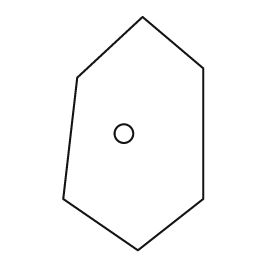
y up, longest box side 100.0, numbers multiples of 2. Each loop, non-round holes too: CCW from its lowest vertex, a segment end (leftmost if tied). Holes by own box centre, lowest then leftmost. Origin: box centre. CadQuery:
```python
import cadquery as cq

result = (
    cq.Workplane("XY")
    .moveTo(2.0, -50.0)
    .lineTo(30.0, -28.0)
    .lineTo(30.0, 28.0)
    .lineTo(4.0, 50.0)
    .lineTo(-24.0, 24.0)
    .lineTo(-30.0, -28.0)
    .close()
    .moveTo(-4.0, 0.0)
    .circle(4.0)
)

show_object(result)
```